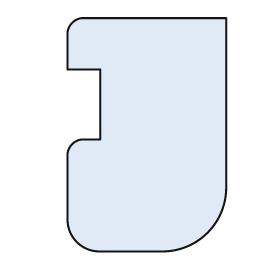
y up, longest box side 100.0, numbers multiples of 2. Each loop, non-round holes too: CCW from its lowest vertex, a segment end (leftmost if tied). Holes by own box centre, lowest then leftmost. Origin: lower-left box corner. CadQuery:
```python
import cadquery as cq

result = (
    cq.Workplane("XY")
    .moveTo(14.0, 0.0)
    .lineTo(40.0, 0.0)
    .threePointArc((60.0, 8.0), (68.0, 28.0))
    .lineTo(68.0, 100.0)
    .lineTo(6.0, 100.0)
    .threePointArc((2.0, 98.0), (0.0, 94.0))
    .lineTo(0.0, 78.0)
    .lineTo(14.0, 78.0)
    .lineTo(14.0, 48.0)
    .lineTo(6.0, 48.0)
    .threePointArc((2.0, 46.0), (0.0, 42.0))
    .lineTo(0.0, 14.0)
    .threePointArc((4.0, 4.0), (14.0, 0.0))
    .close()
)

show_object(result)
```